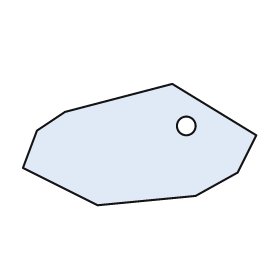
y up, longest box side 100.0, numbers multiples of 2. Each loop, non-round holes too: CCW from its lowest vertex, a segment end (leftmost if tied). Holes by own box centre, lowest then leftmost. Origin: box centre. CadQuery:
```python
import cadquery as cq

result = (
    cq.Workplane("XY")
    .moveTo(-18.0, -26.0)
    .lineTo(24.0, -22.0)
    .lineTo(42.0, -12.0)
    .lineTo(50.0, 4.0)
    .lineTo(14.0, 26.0)
    .lineTo(-32.0, 14.0)
    .lineTo(-44.0, 6.0)
    .lineTo(-50.0, -10.0)
    .close()
    .moveTo(20.0, 8.0)
    .circle(4.0)
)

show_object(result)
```